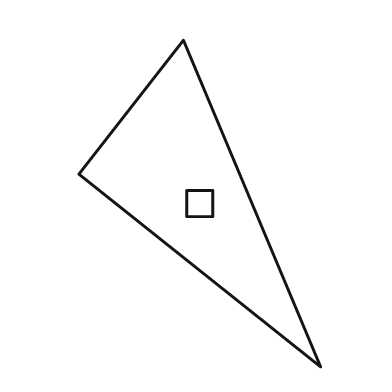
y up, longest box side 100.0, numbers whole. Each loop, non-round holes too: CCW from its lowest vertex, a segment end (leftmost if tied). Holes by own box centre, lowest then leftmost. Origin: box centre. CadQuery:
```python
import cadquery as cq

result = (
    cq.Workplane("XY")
    .moveTo(37.0, -50.0)
    .lineTo(-5.0, 50.0)
    .lineTo(-37.0, 9.0)
    .close()
    .moveTo(-4.0, -4.0)
    .lineTo(4.0, -4.0)
    .lineTo(4.0, 4.0)
    .lineTo(-4.0, 4.0)
    .close()
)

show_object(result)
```